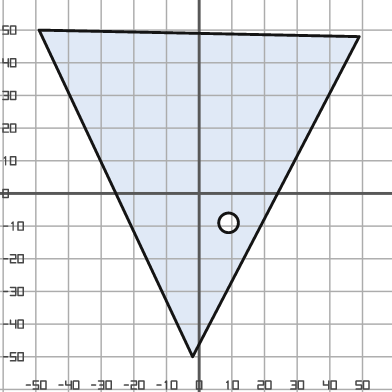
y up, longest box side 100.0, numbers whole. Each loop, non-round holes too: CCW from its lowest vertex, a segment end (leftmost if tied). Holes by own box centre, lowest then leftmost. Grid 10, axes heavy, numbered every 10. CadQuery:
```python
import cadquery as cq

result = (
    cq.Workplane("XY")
    .moveTo(-2.0, -50.0)
    .lineTo(49.0, 48.0)
    .lineTo(-49.0, 50.0)
    .close()
    .moveTo(9.0, -9.0)
    .circle(3.0)
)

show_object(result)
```